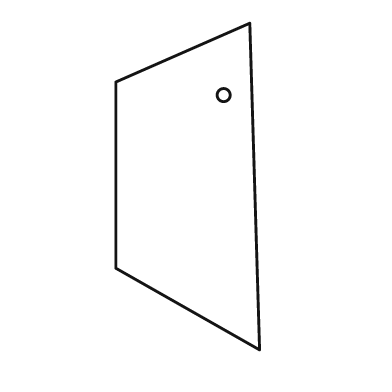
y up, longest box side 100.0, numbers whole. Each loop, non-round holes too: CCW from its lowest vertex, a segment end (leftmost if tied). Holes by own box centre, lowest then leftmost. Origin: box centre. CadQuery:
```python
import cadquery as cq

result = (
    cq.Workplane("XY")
    .moveTo(22.0, -50.0)
    .lineTo(19.0, 50.0)
    .lineTo(-22.0, 32.0)
    .lineTo(-22.0, -25.0)
    .close()
    .moveTo(11.0, 28.0)
    .circle(2.0)
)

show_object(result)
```